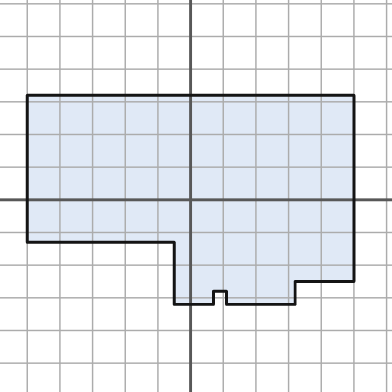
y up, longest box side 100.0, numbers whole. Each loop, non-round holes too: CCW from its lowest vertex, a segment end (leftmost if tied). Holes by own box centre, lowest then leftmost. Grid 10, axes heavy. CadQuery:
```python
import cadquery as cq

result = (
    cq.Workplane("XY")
    .moveTo(-5.0, -32.0)
    .lineTo(7.0, -32.0)
    .lineTo(7.0, -28.0)
    .lineTo(11.0, -28.0)
    .lineTo(11.0, -32.0)
    .lineTo(32.0, -32.0)
    .lineTo(32.0, -25.0)
    .lineTo(50.0, -25.0)
    .lineTo(50.0, 32.0)
    .lineTo(-50.0, 32.0)
    .lineTo(-50.0, -13.0)
    .lineTo(-5.0, -13.0)
    .close()
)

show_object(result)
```